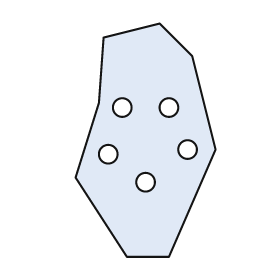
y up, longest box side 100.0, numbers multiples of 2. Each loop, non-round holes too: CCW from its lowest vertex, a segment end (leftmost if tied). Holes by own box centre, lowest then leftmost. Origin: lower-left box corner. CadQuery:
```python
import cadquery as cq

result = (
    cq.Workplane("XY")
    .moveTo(22.0, 0.0)
    .lineTo(40.0, 0.0)
    .lineTo(60.0, 46.0)
    .lineTo(50.0, 86.0)
    .lineTo(36.0, 100.0)
    .lineTo(12.0, 94.0)
    .lineTo(10.0, 66.0)
    .lineTo(0.0, 34.0)
    .close()
    .moveTo(30.0, 32.0)
    .circle(4.0)
    .moveTo(14.0, 44.0)
    .circle(4.0)
    .moveTo(48.0, 46.0)
    .circle(4.0)
    .moveTo(20.0, 64.0)
    .circle(4.0)
    .moveTo(40.0, 64.0)
    .circle(4.0)
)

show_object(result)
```